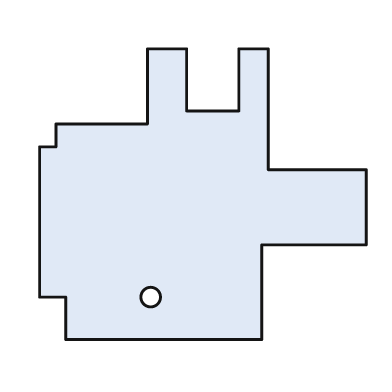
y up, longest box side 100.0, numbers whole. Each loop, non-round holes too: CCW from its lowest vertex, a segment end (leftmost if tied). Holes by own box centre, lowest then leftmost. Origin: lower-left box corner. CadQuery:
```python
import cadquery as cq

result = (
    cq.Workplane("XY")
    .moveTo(8.0, 0.0)
    .lineTo(68.0, 0.0)
    .lineTo(68.0, 29.0)
    .lineTo(100.0, 29.0)
    .lineTo(100.0, 52.0)
    .lineTo(70.0, 52.0)
    .lineTo(70.0, 89.0)
    .lineTo(61.0, 89.0)
    .lineTo(61.0, 70.0)
    .lineTo(45.0, 70.0)
    .lineTo(45.0, 89.0)
    .lineTo(33.0, 89.0)
    .lineTo(33.0, 66.0)
    .lineTo(5.0, 66.0)
    .lineTo(5.0, 59.0)
    .lineTo(0.0, 59.0)
    .lineTo(0.0, 13.0)
    .lineTo(8.0, 13.0)
    .close()
    .moveTo(34.0, 13.0)
    .circle(3.0)
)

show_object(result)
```